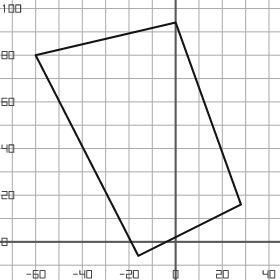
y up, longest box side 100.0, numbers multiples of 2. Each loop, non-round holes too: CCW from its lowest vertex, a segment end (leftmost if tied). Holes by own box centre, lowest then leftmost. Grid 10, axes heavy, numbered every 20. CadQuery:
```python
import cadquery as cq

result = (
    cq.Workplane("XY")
    .moveTo(-16.0, -6.0)
    .lineTo(28.0, 16.0)
    .lineTo(0.0, 94.0)
    .lineTo(-60.0, 80.0)
    .close()
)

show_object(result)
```